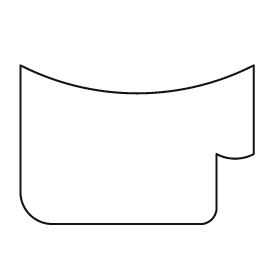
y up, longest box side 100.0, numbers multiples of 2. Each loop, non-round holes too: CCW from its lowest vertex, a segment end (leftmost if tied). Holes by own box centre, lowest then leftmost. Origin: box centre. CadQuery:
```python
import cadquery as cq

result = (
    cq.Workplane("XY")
    .moveTo(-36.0, -34.0)
    .lineTo(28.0, -34.0)
    .threePointArc((32.0, -32.0), (34.0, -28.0))
    .lineTo(34.0, -4.0)
    .threePointArc((42.0, -6.0), (50.0, -4.0))
    .lineTo(50.0, 34.0)
    .threePointArc((0.0, 22.0), (-50.0, 34.0))
    .lineTo(-50.0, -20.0)
    .threePointArc((-46.0, -30.0), (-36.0, -34.0))
    .close()
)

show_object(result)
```